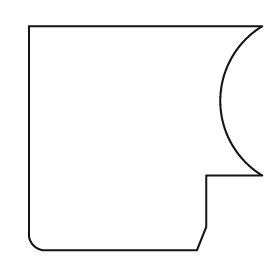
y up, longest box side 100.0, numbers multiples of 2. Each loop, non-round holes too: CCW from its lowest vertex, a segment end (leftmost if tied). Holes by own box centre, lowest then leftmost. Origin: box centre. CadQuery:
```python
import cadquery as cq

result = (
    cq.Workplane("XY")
    .moveTo(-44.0, -48.0)
    .lineTo(22.0, -48.0)
    .lineTo(26.0, -38.0)
    .lineTo(26.0, -16.0)
    .lineTo(50.0, -16.0)
    .threePointArc((32.0, 16.0), (50.0, 48.0))
    .lineTo(-50.0, 48.0)
    .lineTo(-50.0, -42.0)
    .threePointArc((-48.0, -46.0), (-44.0, -48.0))
    .close()
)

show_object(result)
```